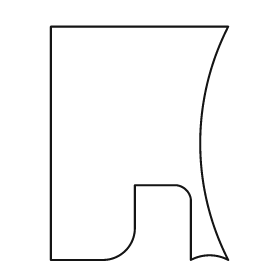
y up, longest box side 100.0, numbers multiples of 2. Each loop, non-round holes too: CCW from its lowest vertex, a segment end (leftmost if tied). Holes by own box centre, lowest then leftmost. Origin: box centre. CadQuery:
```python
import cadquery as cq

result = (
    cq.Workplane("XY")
    .moveTo(-38.0, -50.0)
    .lineTo(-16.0, -50.0)
    .threePointArc((-6.0, -46.0), (-2.0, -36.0))
    .lineTo(-2.0, -18.0)
    .lineTo(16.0, -18.0)
    .threePointArc((20.0, -20.0), (22.0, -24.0))
    .lineTo(22.0, -50.0)
    .threePointArc((30.0, -48.0), (38.0, -50.0))
    .threePointArc((26.0, 0.0), (38.0, 50.0))
    .lineTo(-38.0, 50.0)
    .close()
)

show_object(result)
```